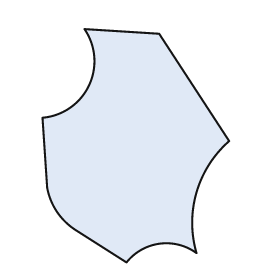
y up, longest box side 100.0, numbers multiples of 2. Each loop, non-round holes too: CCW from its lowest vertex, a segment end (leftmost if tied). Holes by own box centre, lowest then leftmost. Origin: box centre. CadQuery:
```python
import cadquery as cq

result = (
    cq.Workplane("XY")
    .moveTo(-4.0, -50.0)
    .threePointArc((10.0, -42.0), (26.0, -46.0))
    .threePointArc((26.0, -20.0), (40.0, 2.0))
    .lineTo(10.0, 48.0)
    .lineTo(-22.0, 50.0)
    .threePointArc((-20.0, 26.0), (-40.0, 12.0))
    .lineTo(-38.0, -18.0)
    .threePointArc((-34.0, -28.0), (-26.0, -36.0))
    .close()
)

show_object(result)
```